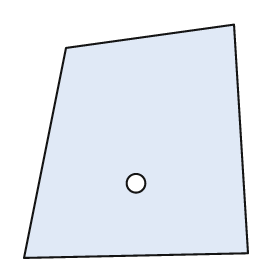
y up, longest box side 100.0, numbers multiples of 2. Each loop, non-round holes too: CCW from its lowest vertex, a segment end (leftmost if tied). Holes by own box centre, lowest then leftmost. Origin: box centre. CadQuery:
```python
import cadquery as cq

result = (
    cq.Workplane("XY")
    .moveTo(-48.0, -50.0)
    .lineTo(48.0, -48.0)
    .lineTo(42.0, 50.0)
    .lineTo(-30.0, 40.0)
    .close()
    .moveTo(0.0, -18.0)
    .circle(4.0)
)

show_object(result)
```